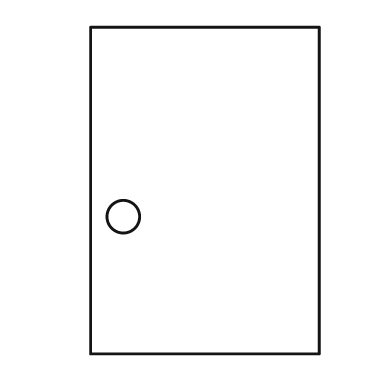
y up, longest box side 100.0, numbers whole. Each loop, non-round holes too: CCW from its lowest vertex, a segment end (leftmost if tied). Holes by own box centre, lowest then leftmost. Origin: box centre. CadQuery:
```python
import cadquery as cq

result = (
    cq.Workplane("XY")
    .moveTo(-35.0, -50.0)
    .lineTo(35.0, -50.0)
    .lineTo(35.0, 50.0)
    .lineTo(-35.0, 50.0)
    .close()
    .moveTo(-25.0, -8.0)
    .circle(5.0)
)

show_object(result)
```